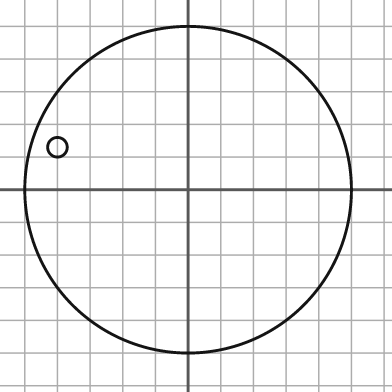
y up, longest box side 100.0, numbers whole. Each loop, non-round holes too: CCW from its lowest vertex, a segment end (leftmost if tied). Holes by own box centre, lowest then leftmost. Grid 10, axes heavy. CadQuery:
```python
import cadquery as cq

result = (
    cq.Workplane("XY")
    .moveTo(0.0, 0.0)
    .circle(50.0)
    .moveTo(-40.0, 13.0)
    .circle(3.0)
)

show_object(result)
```